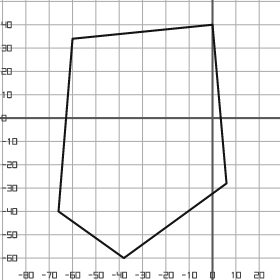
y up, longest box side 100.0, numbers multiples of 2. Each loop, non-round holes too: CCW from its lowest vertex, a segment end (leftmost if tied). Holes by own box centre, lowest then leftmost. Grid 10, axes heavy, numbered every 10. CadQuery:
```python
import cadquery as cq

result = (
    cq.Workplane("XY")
    .moveTo(-38.0, -60.0)
    .lineTo(6.0, -28.0)
    .lineTo(0.0, 40.0)
    .lineTo(-60.0, 34.0)
    .lineTo(-66.0, -40.0)
    .close()
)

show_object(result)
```